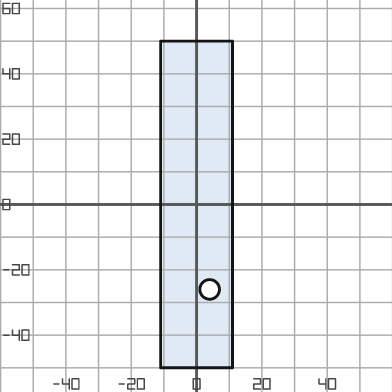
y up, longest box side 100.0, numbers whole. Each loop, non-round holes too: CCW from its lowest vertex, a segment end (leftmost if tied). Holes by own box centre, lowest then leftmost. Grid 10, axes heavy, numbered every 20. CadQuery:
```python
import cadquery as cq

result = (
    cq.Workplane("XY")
    .moveTo(-11.0, -50.0)
    .lineTo(11.0, -50.0)
    .lineTo(11.0, 50.0)
    .lineTo(-11.0, 50.0)
    .close()
    .moveTo(4.0, -26.0)
    .circle(3.0)
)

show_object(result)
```